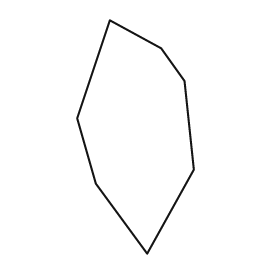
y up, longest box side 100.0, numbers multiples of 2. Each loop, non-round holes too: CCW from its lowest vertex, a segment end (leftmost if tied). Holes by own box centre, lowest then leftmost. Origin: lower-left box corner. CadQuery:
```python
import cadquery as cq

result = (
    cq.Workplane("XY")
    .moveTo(30.0, 0.0)
    .lineTo(50.0, 36.0)
    .lineTo(46.0, 74.0)
    .lineTo(36.0, 88.0)
    .lineTo(14.0, 100.0)
    .lineTo(0.0, 58.0)
    .lineTo(8.0, 30.0)
    .close()
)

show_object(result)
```